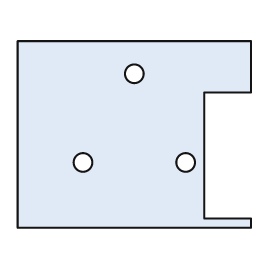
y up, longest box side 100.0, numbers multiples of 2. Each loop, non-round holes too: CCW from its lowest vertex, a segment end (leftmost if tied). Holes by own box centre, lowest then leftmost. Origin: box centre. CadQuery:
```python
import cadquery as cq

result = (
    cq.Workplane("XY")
    .moveTo(-50.0, -40.0)
    .lineTo(50.0, -40.0)
    .lineTo(50.0, -36.0)
    .lineTo(30.0, -36.0)
    .lineTo(30.0, 18.0)
    .lineTo(50.0, 18.0)
    .lineTo(50.0, 40.0)
    .lineTo(-50.0, 40.0)
    .close()
    .moveTo(-22.0, -12.0)
    .circle(4.0)
    .moveTo(22.0, -12.0)
    .circle(4.0)
    .moveTo(0.0, 26.0)
    .circle(4.0)
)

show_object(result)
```